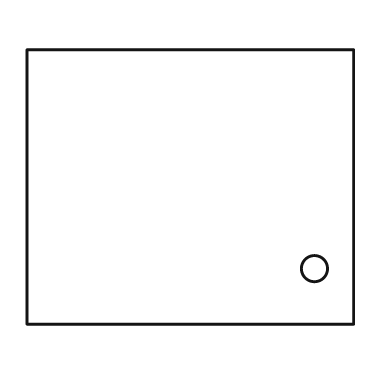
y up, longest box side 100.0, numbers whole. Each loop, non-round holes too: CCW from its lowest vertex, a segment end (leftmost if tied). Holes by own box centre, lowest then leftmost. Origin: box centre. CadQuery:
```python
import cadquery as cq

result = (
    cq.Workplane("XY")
    .moveTo(-50.0, -42.0)
    .lineTo(50.0, -42.0)
    .lineTo(50.0, 42.0)
    .lineTo(-50.0, 42.0)
    .close()
    .moveTo(38.0, -25.0)
    .circle(4.0)
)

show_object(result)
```